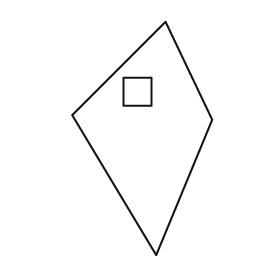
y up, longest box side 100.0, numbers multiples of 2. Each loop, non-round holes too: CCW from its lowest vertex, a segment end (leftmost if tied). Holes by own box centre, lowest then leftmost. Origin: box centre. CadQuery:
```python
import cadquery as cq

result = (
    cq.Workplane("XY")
    .moveTo(6.0, -50.0)
    .lineTo(30.0, 8.0)
    .lineTo(10.0, 50.0)
    .lineTo(-30.0, 10.0)
    .close()
    .moveTo(-8.0, 14.0)
    .lineTo(4.0, 14.0)
    .lineTo(4.0, 26.0)
    .lineTo(-8.0, 26.0)
    .close()
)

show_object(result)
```